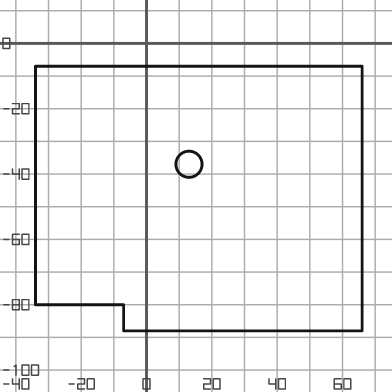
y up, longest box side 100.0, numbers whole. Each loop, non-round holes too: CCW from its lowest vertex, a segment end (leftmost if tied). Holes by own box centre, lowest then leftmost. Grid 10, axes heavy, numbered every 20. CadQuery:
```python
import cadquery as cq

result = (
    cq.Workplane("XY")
    .moveTo(-7.0, -88.0)
    .lineTo(66.0, -88.0)
    .lineTo(66.0, -7.0)
    .lineTo(-34.0, -7.0)
    .lineTo(-34.0, -80.0)
    .lineTo(-7.0, -80.0)
    .close()
    .moveTo(13.0, -37.0)
    .circle(4.0)
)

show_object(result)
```